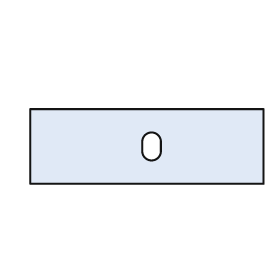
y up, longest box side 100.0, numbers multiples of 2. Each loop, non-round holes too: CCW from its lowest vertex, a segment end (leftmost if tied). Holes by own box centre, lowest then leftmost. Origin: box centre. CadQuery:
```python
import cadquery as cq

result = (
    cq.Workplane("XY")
    .moveTo(-50.0, -16.0)
    .lineTo(50.0, -16.0)
    .lineTo(50.0, 16.0)
    .lineTo(-50.0, 16.0)
    .close()
    .moveTo(-2.0, -2.0)
    .threePointArc((2.0, -6.0), (6.0, -2.0))
    .lineTo(6.0, 2.0)
    .threePointArc((2.0, 6.0), (-2.0, 2.0))
    .close()
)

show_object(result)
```